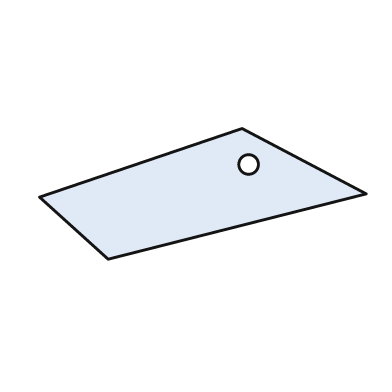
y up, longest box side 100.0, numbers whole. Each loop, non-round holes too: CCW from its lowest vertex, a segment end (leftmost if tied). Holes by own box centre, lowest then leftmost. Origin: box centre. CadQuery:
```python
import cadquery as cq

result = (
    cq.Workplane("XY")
    .moveTo(-29.0, -20.0)
    .lineTo(50.0, 0.0)
    .lineTo(12.0, 20.0)
    .lineTo(-50.0, -1.0)
    .close()
    .moveTo(14.0, 9.0)
    .circle(3.0)
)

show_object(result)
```